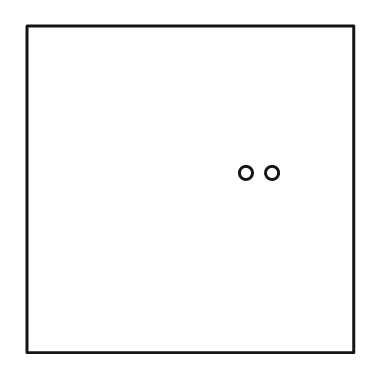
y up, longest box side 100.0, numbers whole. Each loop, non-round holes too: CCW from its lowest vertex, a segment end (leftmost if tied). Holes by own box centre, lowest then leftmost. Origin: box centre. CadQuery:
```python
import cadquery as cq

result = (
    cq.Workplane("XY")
    .moveTo(-50.0, -50.0)
    .lineTo(50.0, -50.0)
    .lineTo(50.0, 50.0)
    .lineTo(-50.0, 50.0)
    .close()
    .moveTo(17.0, 5.0)
    .circle(2.0)
    .moveTo(25.0, 5.0)
    .circle(2.0)
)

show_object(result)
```